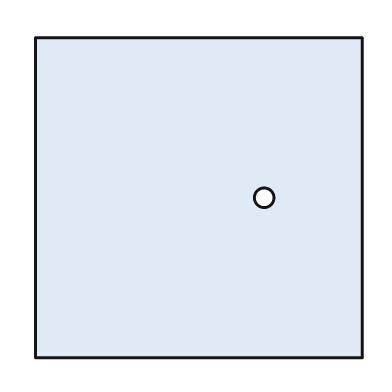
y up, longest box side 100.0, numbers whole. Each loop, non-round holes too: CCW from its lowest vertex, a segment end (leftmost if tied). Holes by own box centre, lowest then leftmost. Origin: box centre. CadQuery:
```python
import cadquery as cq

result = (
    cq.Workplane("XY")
    .moveTo(-50.0, -49.0)
    .lineTo(50.0, -49.0)
    .lineTo(50.0, 49.0)
    .lineTo(-50.0, 49.0)
    .close()
    .moveTo(20.0, 0.0)
    .circle(3.0)
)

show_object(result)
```